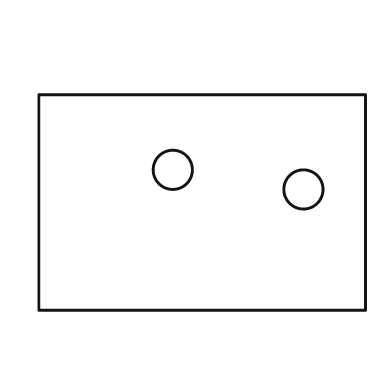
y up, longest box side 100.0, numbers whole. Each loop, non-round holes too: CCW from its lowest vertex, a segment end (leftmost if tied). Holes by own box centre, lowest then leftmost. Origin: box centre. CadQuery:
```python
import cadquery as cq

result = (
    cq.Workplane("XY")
    .moveTo(-50.0, -33.0)
    .lineTo(50.0, -33.0)
    .lineTo(50.0, 33.0)
    .lineTo(-50.0, 33.0)
    .close()
    .moveTo(31.0, 4.0)
    .circle(6.0)
    .moveTo(-9.0, 10.0)
    .circle(6.0)
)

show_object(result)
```